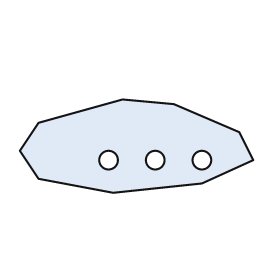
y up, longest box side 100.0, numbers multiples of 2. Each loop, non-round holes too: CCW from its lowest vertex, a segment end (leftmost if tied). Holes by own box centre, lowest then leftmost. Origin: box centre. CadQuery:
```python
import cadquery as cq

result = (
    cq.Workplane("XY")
    .moveTo(-10.0, -20.0)
    .lineTo(28.0, -16.0)
    .lineTo(50.0, -6.0)
    .lineTo(44.0, 6.0)
    .lineTo(16.0, 18.0)
    .lineTo(-6.0, 20.0)
    .lineTo(-42.0, 10.0)
    .lineTo(-50.0, -2.0)
    .lineTo(-42.0, -14.0)
    .close()
    .moveTo(-12.0, -6.0)
    .circle(4.0)
    .moveTo(8.0, -6.0)
    .circle(4.0)
    .moveTo(28.0, -6.0)
    .circle(4.0)
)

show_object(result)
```